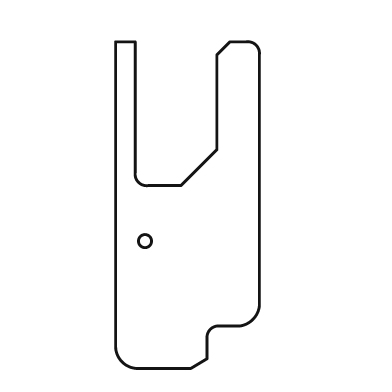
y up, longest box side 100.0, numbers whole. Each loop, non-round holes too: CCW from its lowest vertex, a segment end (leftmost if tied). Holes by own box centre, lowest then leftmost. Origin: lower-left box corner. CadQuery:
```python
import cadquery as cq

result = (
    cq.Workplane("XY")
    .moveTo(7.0, 0.0)
    .lineTo(23.0, 0.0)
    .lineTo(28.0, 3.0)
    .lineTo(28.0, 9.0)
    .threePointArc((29.0, 12.0), (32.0, 13.0))
    .lineTo(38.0, 13.0)
    .threePointArc((42.0, 15.0), (44.0, 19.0))
    .lineTo(44.0, 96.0)
    .threePointArc((43.0, 99.0), (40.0, 100.0))
    .lineTo(35.0, 100.0)
    .lineTo(31.0, 96.0)
    .lineTo(31.0, 67.0)
    .lineTo(20.0, 56.0)
    .lineTo(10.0, 56.0)
    .threePointArc((7.0, 57.0), (6.0, 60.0))
    .lineTo(6.0, 100.0)
    .lineTo(0.0, 100.0)
    .lineTo(0.0, 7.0)
    .threePointArc((2.0, 2.0), (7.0, 0.0))
    .close()
    .moveTo(9.0, 39.0)
    .circle(2.0)
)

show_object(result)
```